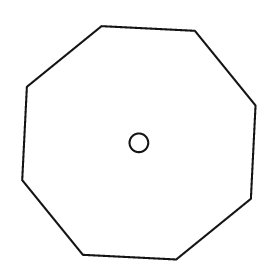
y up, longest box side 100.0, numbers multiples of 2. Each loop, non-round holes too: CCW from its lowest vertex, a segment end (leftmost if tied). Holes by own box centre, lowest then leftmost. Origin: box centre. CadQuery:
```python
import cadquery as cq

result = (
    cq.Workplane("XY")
    .moveTo(16.0, -50.0)
    .lineTo(48.0, -24.0)
    .lineTo(50.0, 16.0)
    .lineTo(24.0, 48.0)
    .lineTo(-16.0, 50.0)
    .lineTo(-48.0, 24.0)
    .lineTo(-50.0, -16.0)
    .lineTo(-24.0, -48.0)
    .close()
    .moveTo(0.0, 0.0)
    .circle(4.0)
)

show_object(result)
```